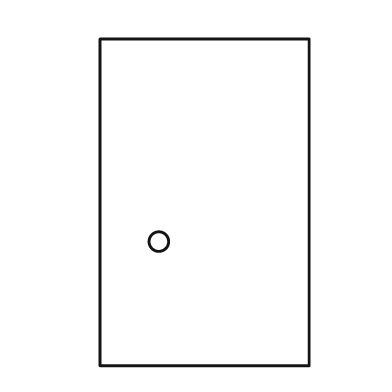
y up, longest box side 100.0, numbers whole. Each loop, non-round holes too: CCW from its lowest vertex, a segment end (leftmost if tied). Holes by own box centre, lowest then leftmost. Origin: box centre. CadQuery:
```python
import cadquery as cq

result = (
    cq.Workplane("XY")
    .moveTo(-32.0, -50.0)
    .lineTo(32.0, -50.0)
    .lineTo(32.0, 50.0)
    .lineTo(-32.0, 50.0)
    .close()
    .moveTo(-14.0, -12.0)
    .circle(3.0)
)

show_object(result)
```